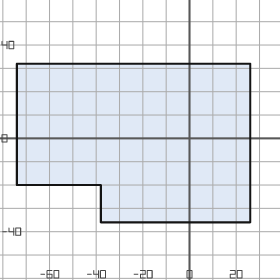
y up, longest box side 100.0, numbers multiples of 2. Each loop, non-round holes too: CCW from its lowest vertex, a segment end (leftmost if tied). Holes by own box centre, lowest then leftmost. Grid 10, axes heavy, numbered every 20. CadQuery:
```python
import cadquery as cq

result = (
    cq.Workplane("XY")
    .moveTo(-38.0, -36.0)
    .lineTo(26.0, -36.0)
    .lineTo(26.0, 32.0)
    .lineTo(-74.0, 32.0)
    .lineTo(-74.0, -20.0)
    .lineTo(-38.0, -20.0)
    .close()
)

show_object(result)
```